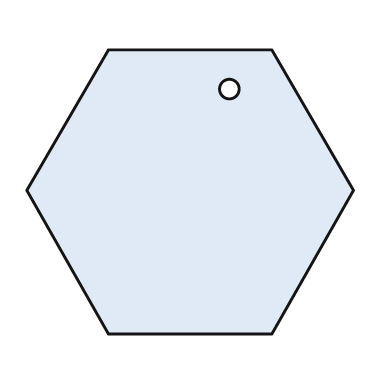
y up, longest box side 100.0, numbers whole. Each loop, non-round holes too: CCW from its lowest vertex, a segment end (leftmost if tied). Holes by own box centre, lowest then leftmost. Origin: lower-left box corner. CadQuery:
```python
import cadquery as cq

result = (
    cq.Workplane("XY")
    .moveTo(25.0, 0.0)
    .lineTo(75.0, 0.0)
    .lineTo(100.0, 44.0)
    .lineTo(75.0, 87.0)
    .lineTo(25.0, 87.0)
    .lineTo(0.0, 44.0)
    .close()
    .moveTo(62.0, 75.0)
    .circle(3.0)
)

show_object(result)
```